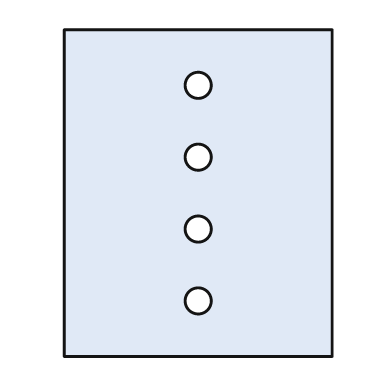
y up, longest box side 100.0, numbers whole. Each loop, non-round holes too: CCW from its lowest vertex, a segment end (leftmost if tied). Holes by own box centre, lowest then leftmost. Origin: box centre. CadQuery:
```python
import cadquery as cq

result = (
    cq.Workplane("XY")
    .moveTo(-41.0, -50.0)
    .lineTo(41.0, -50.0)
    .lineTo(41.0, 50.0)
    .lineTo(-41.0, 50.0)
    .close()
    .moveTo(0.0, -33.0)
    .circle(4.0)
    .moveTo(0.0, -11.0)
    .circle(4.0)
    .moveTo(0.0, 11.0)
    .circle(4.0)
    .moveTo(0.0, 33.0)
    .circle(4.0)
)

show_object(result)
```